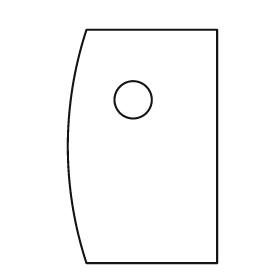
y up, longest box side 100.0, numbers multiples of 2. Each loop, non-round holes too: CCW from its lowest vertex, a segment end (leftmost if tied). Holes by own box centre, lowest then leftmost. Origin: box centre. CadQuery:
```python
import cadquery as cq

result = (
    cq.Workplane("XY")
    .moveTo(-24.0, -50.0)
    .lineTo(32.0, -50.0)
    .lineTo(32.0, 50.0)
    .lineTo(-24.0, 50.0)
    .threePointArc((-32.0, 0.0), (-24.0, -50.0))
    .close()
    .moveTo(-4.0, 20.0)
    .circle(8.0)
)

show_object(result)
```